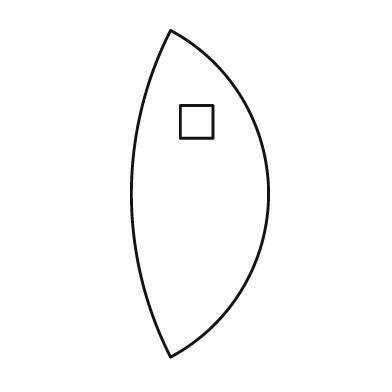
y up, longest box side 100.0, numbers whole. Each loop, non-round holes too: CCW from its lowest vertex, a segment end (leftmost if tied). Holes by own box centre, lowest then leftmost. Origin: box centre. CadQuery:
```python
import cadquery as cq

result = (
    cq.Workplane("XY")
    .moveTo(-9.0, -50.0)
    .threePointArc((21.0, 0.0), (-9.0, 50.0))
    .threePointArc((-21.0, 0.0), (-9.0, -50.0))
    .close()
    .moveTo(-6.0, 17.0)
    .lineTo(4.0, 17.0)
    .lineTo(4.0, 27.0)
    .lineTo(-6.0, 27.0)
    .close()
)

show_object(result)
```